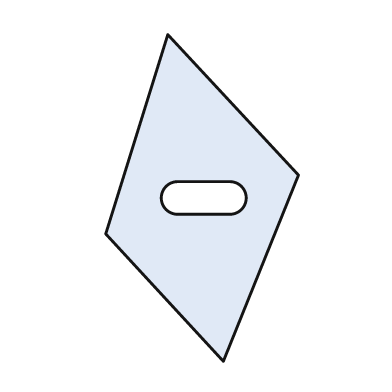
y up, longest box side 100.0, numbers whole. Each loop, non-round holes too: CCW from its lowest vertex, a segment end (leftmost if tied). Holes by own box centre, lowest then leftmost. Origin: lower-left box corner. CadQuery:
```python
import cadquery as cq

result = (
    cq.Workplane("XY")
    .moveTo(36.0, 0.0)
    .lineTo(59.0, 57.0)
    .lineTo(19.0, 100.0)
    .lineTo(0.0, 39.0)
    .close()
    .moveTo(22.0, 45.0)
    .lineTo(38.0, 45.0)
    .threePointArc((43.0, 50.0), (38.0, 55.0))
    .lineTo(22.0, 55.0)
    .threePointArc((17.0, 50.0), (22.0, 45.0))
    .close()
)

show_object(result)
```